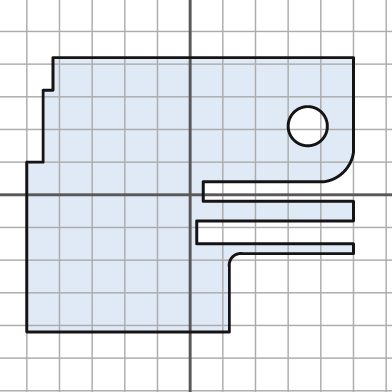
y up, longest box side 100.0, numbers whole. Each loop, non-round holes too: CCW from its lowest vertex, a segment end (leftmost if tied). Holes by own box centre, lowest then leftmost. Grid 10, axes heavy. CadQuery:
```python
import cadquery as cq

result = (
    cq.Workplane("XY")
    .moveTo(-50.0, -42.0)
    .lineTo(12.0, -42.0)
    .lineTo(12.0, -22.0)
    .threePointArc((13.0, -19.0), (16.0, -18.0))
    .lineTo(50.0, -18.0)
    .lineTo(50.0, -15.0)
    .lineTo(2.0, -15.0)
    .lineTo(2.0, -8.0)
    .lineTo(50.0, -8.0)
    .lineTo(50.0, -2.0)
    .lineTo(4.0, -2.0)
    .lineTo(4.0, 4.0)
    .lineTo(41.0, 4.0)
    .threePointArc((47.0, 7.0), (50.0, 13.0))
    .lineTo(50.0, 42.0)
    .lineTo(-42.0, 42.0)
    .lineTo(-42.0, 32.0)
    .lineTo(-45.0, 32.0)
    .lineTo(-45.0, 10.0)
    .lineTo(-50.0, 10.0)
    .close()
    .moveTo(36.0, 21.0)
    .circle(6.0)
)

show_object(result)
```